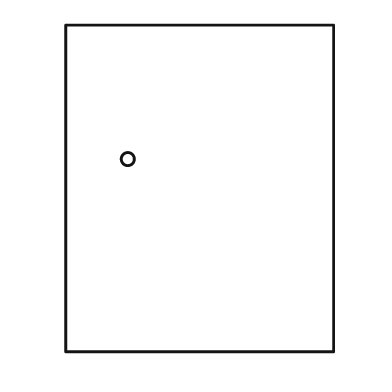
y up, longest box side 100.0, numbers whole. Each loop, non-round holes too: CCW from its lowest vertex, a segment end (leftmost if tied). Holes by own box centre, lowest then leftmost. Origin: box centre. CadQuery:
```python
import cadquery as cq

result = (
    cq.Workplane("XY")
    .moveTo(-41.0, -50.0)
    .lineTo(41.0, -50.0)
    .lineTo(41.0, 50.0)
    .lineTo(-41.0, 50.0)
    .close()
    .moveTo(-22.0, 9.0)
    .circle(2.0)
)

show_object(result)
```